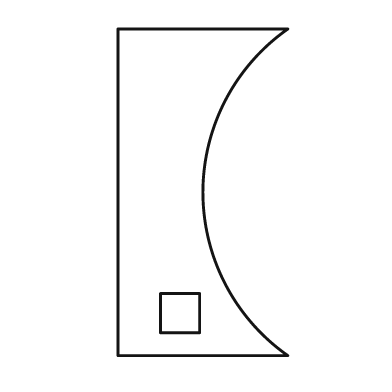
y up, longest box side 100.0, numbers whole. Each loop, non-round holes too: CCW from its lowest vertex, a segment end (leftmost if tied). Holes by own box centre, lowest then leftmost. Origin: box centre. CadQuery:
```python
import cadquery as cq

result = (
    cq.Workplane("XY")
    .moveTo(-26.0, -50.0)
    .lineTo(26.0, -50.0)
    .threePointArc((0.0, 0.0), (26.0, 50.0))
    .lineTo(-26.0, 50.0)
    .close()
    .moveTo(-13.0, -43.0)
    .lineTo(-1.0, -43.0)
    .lineTo(-1.0, -31.0)
    .lineTo(-13.0, -31.0)
    .close()
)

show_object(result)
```